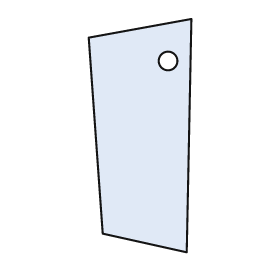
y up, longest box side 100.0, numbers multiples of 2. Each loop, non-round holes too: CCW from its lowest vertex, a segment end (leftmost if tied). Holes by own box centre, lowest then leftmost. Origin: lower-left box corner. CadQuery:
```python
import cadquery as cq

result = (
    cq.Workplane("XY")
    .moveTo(42.0, 0.0)
    .lineTo(44.0, 100.0)
    .lineTo(0.0, 92.0)
    .lineTo(6.0, 8.0)
    .close()
    .moveTo(34.0, 82.0)
    .circle(4.0)
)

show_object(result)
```